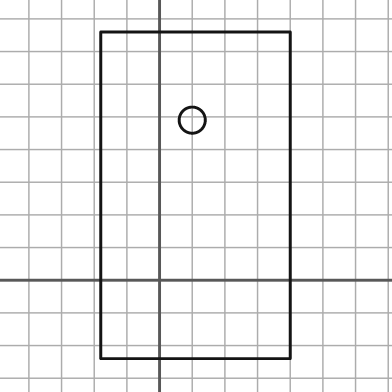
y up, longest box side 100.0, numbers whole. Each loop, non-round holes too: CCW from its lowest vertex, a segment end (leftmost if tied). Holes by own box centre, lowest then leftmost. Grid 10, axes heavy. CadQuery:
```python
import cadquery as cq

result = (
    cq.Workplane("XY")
    .moveTo(-18.0, -24.0)
    .lineTo(40.0, -24.0)
    .lineTo(40.0, 76.0)
    .lineTo(-18.0, 76.0)
    .close()
    .moveTo(10.0, 49.0)
    .circle(4.0)
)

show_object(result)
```